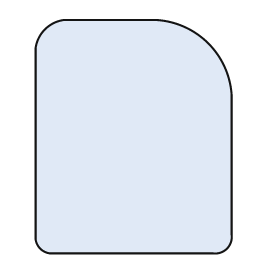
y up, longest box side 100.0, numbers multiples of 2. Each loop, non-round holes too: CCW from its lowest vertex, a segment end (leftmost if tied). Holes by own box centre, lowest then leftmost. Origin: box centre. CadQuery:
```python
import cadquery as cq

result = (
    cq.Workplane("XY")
    .moveTo(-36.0, -50.0)
    .lineTo(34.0, -50.0)
    .threePointArc((40.0, -48.0), (42.0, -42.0))
    .lineTo(42.0, 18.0)
    .threePointArc((32.0, 40.0), (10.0, 50.0))
    .lineTo(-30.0, 50.0)
    .threePointArc((-38.0, 46.0), (-42.0, 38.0))
    .lineTo(-42.0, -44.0)
    .threePointArc((-40.0, -48.0), (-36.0, -50.0))
    .close()
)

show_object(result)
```